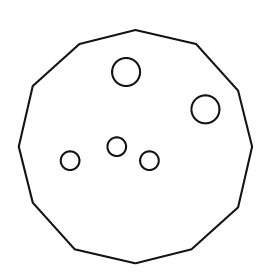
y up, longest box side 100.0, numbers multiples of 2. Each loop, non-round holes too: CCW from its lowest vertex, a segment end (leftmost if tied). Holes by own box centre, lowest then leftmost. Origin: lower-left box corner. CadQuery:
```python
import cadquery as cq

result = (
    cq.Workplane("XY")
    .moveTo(50.0, 0.0)
    .lineTo(74.0, 6.0)
    .lineTo(94.0, 24.0)
    .lineTo(100.0, 50.0)
    .lineTo(94.0, 74.0)
    .lineTo(76.0, 94.0)
    .lineTo(50.0, 100.0)
    .lineTo(26.0, 94.0)
    .lineTo(6.0, 76.0)
    .lineTo(0.0, 50.0)
    .lineTo(6.0, 26.0)
    .lineTo(24.0, 6.0)
    .close()
    .moveTo(22.0, 44.0)
    .circle(4.0)
    .moveTo(56.0, 44.0)
    .circle(4.0)
    .moveTo(42.0, 50.0)
    .circle(4.0)
    .moveTo(80.0, 66.0)
    .circle(6.0)
    .moveTo(46.0, 82.0)
    .circle(6.0)
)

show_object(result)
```